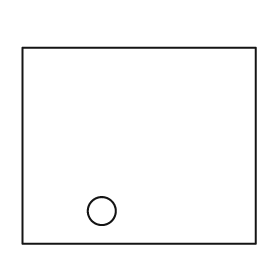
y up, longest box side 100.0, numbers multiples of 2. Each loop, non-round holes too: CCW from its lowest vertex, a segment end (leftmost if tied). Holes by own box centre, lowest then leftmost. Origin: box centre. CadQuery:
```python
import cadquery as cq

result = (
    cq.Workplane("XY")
    .moveTo(-50.0, -42.0)
    .lineTo(50.0, -42.0)
    .lineTo(50.0, 42.0)
    .lineTo(-50.0, 42.0)
    .close()
    .moveTo(-16.0, -28.0)
    .circle(6.0)
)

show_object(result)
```